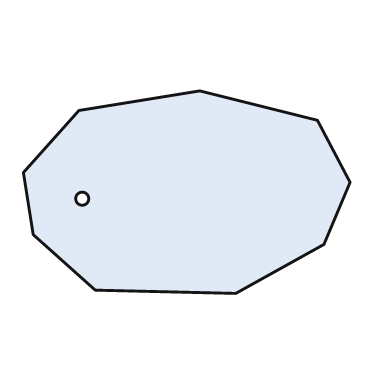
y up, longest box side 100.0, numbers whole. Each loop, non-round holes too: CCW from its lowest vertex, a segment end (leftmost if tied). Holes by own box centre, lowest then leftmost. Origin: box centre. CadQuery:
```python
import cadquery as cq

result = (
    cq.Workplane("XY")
    .moveTo(15.0, -31.0)
    .lineTo(42.0, -16.0)
    .lineTo(50.0, 3.0)
    .lineTo(40.0, 22.0)
    .lineTo(4.0, 31.0)
    .lineTo(-33.0, 25.0)
    .lineTo(-50.0, 6.0)
    .lineTo(-47.0, -13.0)
    .lineTo(-28.0, -30.0)
    .close()
    .moveTo(-32.0, -2.0)
    .circle(2.0)
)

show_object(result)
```